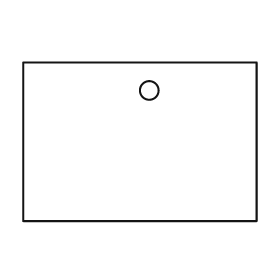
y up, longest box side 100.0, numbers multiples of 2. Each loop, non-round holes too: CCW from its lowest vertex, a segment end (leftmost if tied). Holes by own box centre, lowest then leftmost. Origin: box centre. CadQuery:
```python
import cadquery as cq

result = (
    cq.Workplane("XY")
    .moveTo(-50.0, -34.0)
    .lineTo(50.0, -34.0)
    .lineTo(50.0, 34.0)
    .lineTo(-50.0, 34.0)
    .close()
    .moveTo(4.0, 22.0)
    .circle(4.0)
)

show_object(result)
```